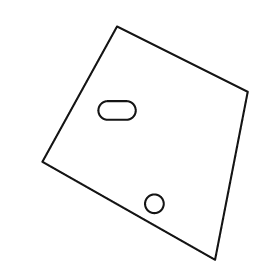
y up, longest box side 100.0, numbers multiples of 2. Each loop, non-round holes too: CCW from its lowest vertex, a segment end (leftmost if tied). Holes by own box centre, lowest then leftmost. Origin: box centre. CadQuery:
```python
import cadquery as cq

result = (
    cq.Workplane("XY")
    .moveTo(30.0, -50.0)
    .lineTo(44.0, 22.0)
    .lineTo(-12.0, 50.0)
    .lineTo(-44.0, -8.0)
    .close()
    .moveTo(4.0, -26.0)
    .circle(4.0)
    .moveTo(-16.0, 10.0)
    .lineTo(-8.0, 10.0)
    .threePointArc((-4.0, 14.0), (-8.0, 18.0))
    .lineTo(-16.0, 18.0)
    .threePointArc((-20.0, 14.0), (-16.0, 10.0))
    .close()
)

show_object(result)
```